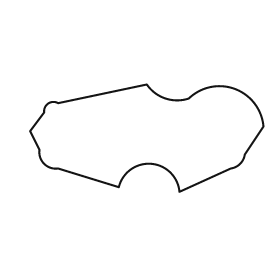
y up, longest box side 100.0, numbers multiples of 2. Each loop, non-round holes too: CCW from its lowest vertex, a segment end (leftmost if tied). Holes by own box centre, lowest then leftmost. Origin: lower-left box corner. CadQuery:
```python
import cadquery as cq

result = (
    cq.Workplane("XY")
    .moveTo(64.0, 0.0)
    .lineTo(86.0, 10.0)
    .threePointArc((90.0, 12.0), (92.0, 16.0))
    .lineTo(100.0, 28.0)
    .threePointArc((88.0, 44.0), (68.0, 40.0))
    .threePointArc((58.0, 40.0), (50.0, 46.0))
    .lineTo(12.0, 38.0)
    .threePointArc((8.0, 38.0), (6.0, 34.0))
    .lineTo(0.0, 26.0)
    .lineTo(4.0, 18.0)
    .threePointArc((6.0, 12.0), (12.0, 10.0))
    .lineTo(38.0, 2.0)
    .threePointArc((52.0, 12.0), (64.0, 0.0))
    .close()
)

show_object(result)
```